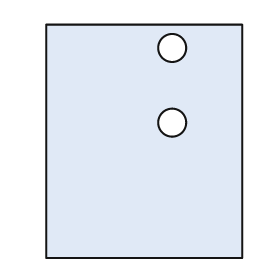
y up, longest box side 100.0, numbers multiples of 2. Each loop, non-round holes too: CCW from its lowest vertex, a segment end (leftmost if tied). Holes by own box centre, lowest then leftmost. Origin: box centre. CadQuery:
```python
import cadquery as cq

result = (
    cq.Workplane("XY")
    .moveTo(-42.0, -50.0)
    .lineTo(42.0, -50.0)
    .lineTo(42.0, 50.0)
    .lineTo(-42.0, 50.0)
    .close()
    .moveTo(12.0, 8.0)
    .circle(6.0)
    .moveTo(12.0, 40.0)
    .circle(6.0)
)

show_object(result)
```